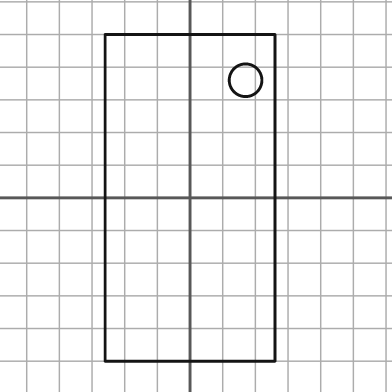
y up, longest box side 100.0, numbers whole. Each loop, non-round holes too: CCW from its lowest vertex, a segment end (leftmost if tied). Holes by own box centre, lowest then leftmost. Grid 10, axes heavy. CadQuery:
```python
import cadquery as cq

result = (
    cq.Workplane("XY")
    .moveTo(-26.0, -50.0)
    .lineTo(26.0, -50.0)
    .lineTo(26.0, 50.0)
    .lineTo(-26.0, 50.0)
    .close()
    .moveTo(17.0, 36.0)
    .circle(5.0)
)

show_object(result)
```